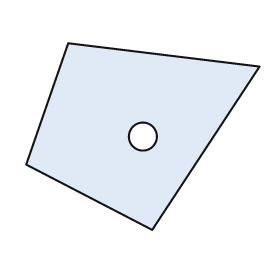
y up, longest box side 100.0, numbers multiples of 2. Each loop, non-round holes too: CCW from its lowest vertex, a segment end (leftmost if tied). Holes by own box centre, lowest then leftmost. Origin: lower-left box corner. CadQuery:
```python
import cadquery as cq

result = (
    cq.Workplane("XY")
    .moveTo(54.0, 0.0)
    .lineTo(100.0, 70.0)
    .lineTo(18.0, 80.0)
    .lineTo(0.0, 28.0)
    .close()
    .moveTo(50.0, 40.0)
    .circle(6.0)
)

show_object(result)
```